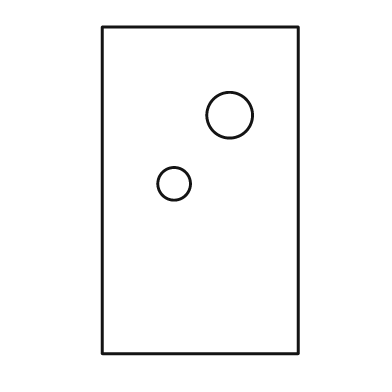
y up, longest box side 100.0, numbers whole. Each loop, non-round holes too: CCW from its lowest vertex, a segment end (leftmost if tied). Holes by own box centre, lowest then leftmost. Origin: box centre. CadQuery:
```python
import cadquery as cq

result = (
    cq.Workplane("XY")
    .moveTo(-30.0, -50.0)
    .lineTo(30.0, -50.0)
    .lineTo(30.0, 50.0)
    .lineTo(-30.0, 50.0)
    .close()
    .moveTo(-8.0, 2.0)
    .circle(5.0)
    .moveTo(9.0, 23.0)
    .circle(7.0)
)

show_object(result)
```